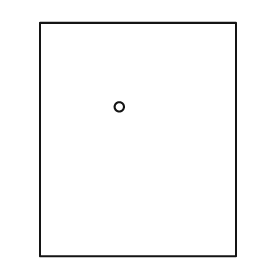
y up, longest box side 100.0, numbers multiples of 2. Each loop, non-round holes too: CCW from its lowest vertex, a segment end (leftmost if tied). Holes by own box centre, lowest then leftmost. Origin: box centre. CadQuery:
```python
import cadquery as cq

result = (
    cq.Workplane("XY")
    .moveTo(-42.0, -50.0)
    .lineTo(42.0, -50.0)
    .lineTo(42.0, 50.0)
    .lineTo(-42.0, 50.0)
    .close()
    .moveTo(-8.0, 14.0)
    .circle(2.0)
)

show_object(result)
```